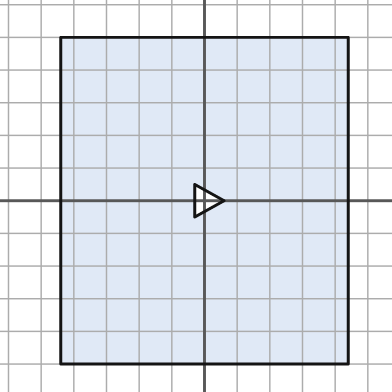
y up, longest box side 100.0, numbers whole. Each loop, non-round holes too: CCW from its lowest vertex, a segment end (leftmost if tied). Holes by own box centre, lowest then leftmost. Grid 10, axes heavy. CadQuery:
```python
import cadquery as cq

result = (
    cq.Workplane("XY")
    .moveTo(-44.0, -50.0)
    .lineTo(44.0, -50.0)
    .lineTo(44.0, 50.0)
    .lineTo(-44.0, 50.0)
    .close()
    .moveTo(-3.0, -5.0)
    .lineTo(6.0, 0.0)
    .lineTo(-3.0, 5.0)
    .close()
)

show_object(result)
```